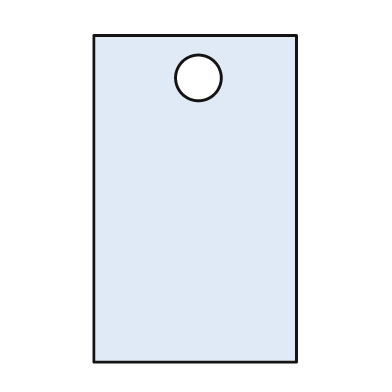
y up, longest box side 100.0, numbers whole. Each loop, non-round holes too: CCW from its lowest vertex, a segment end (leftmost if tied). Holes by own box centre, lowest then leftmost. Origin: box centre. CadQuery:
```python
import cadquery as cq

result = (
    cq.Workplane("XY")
    .moveTo(-31.0, -50.0)
    .lineTo(31.0, -50.0)
    .lineTo(31.0, 50.0)
    .lineTo(-31.0, 50.0)
    .close()
    .moveTo(1.0, 37.0)
    .circle(7.0)
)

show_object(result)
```